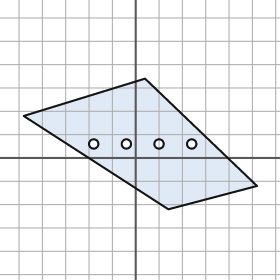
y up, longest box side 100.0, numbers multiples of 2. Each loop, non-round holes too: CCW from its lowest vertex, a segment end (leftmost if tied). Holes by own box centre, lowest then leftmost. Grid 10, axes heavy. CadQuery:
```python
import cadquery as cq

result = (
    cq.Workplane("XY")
    .moveTo(14.0, -22.0)
    .lineTo(52.0, -12.0)
    .lineTo(4.0, 34.0)
    .lineTo(-48.0, 18.0)
    .close()
    .moveTo(-18.0, 6.0)
    .circle(2.0)
    .moveTo(-4.0, 6.0)
    .circle(2.0)
    .moveTo(10.0, 6.0)
    .circle(2.0)
    .moveTo(24.0, 6.0)
    .circle(2.0)
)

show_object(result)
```